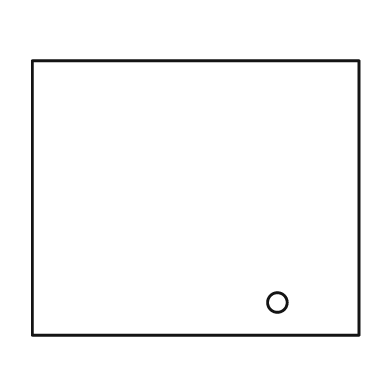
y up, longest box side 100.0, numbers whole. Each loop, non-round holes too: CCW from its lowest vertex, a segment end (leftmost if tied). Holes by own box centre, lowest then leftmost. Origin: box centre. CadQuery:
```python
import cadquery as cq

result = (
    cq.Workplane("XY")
    .moveTo(-50.0, -42.0)
    .lineTo(50.0, -42.0)
    .lineTo(50.0, 42.0)
    .lineTo(-50.0, 42.0)
    .close()
    .moveTo(25.0, -32.0)
    .circle(3.0)
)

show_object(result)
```